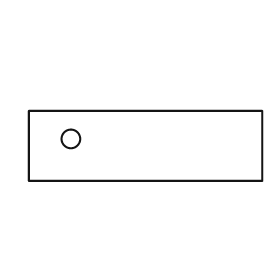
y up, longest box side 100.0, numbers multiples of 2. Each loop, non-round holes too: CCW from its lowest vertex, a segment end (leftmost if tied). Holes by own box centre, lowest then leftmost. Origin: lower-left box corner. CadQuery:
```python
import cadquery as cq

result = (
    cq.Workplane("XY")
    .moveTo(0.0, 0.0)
    .lineTo(100.0, 0.0)
    .lineTo(100.0, 30.0)
    .lineTo(0.0, 30.0)
    .close()
    .moveTo(18.0, 18.0)
    .circle(4.0)
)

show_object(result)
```